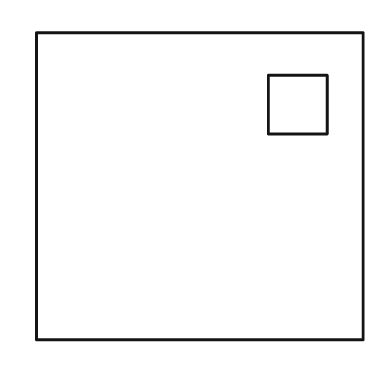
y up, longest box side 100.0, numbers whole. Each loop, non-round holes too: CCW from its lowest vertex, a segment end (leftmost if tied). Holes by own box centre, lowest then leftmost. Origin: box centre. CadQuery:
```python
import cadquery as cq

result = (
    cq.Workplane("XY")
    .moveTo(-50.0, -47.0)
    .lineTo(50.0, -47.0)
    .lineTo(50.0, 47.0)
    .lineTo(-50.0, 47.0)
    .close()
    .moveTo(21.0, 16.0)
    .lineTo(39.0, 16.0)
    .lineTo(39.0, 34.0)
    .lineTo(21.0, 34.0)
    .close()
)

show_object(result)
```